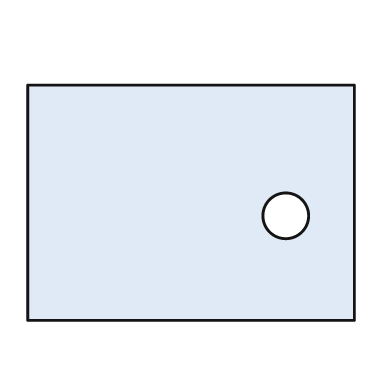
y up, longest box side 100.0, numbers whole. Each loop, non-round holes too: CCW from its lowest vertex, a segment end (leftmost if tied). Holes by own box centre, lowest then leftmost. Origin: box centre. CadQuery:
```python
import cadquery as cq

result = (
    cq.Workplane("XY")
    .moveTo(-50.0, -36.0)
    .lineTo(50.0, -36.0)
    .lineTo(50.0, 36.0)
    .lineTo(-50.0, 36.0)
    .close()
    .moveTo(29.0, -4.0)
    .circle(7.0)
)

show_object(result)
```